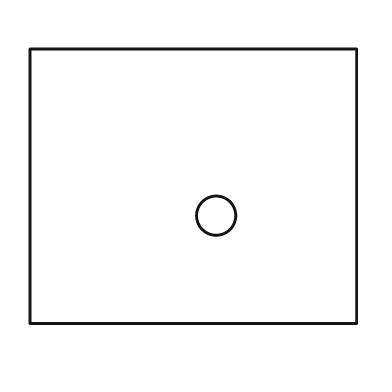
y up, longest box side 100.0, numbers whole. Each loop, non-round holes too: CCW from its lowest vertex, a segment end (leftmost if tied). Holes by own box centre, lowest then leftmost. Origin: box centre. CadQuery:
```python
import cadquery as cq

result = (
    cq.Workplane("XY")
    .moveTo(-50.0, -42.0)
    .lineTo(50.0, -42.0)
    .lineTo(50.0, 42.0)
    .lineTo(-50.0, 42.0)
    .close()
    .moveTo(7.0, -9.0)
    .circle(6.0)
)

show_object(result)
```